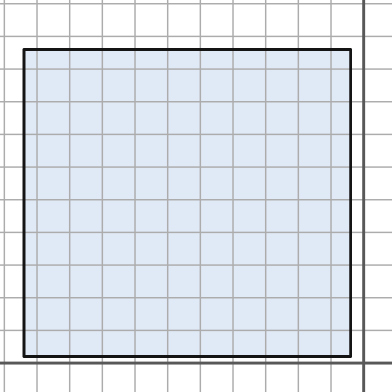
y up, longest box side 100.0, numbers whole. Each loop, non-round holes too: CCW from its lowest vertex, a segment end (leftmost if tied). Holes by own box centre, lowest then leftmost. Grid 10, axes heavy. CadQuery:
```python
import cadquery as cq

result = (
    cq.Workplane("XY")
    .moveTo(-104.0, 2.0)
    .lineTo(-4.0, 2.0)
    .lineTo(-4.0, 96.0)
    .lineTo(-104.0, 96.0)
    .close()
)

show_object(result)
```